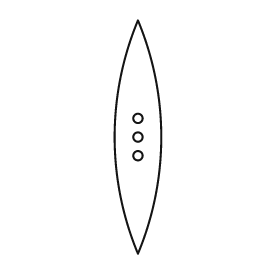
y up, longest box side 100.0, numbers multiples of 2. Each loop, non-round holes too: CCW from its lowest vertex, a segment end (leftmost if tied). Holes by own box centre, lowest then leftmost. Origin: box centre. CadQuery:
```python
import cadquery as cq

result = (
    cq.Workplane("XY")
    .moveTo(0.0, -50.0)
    .threePointArc((10.0, 0.0), (0.0, 50.0))
    .threePointArc((-10.0, 0.0), (0.0, -50.0))
    .close()
    .moveTo(0.0, -8.0)
    .circle(2.0)
    .moveTo(0.0, 0.0)
    .circle(2.0)
    .moveTo(0.0, 8.0)
    .circle(2.0)
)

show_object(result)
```